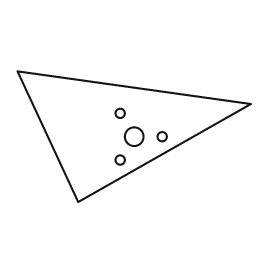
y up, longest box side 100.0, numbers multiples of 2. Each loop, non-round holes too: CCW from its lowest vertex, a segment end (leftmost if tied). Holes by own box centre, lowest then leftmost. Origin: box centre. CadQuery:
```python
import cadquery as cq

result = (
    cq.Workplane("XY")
    .moveTo(-24.0, -28.0)
    .lineTo(50.0, 14.0)
    .lineTo(-50.0, 28.0)
    .close()
    .moveTo(-6.0, -10.0)
    .circle(2.0)
    .moveTo(0.0, 0.0)
    .circle(4.0)
    .moveTo(12.0, 0.0)
    .circle(2.0)
    .moveTo(-6.0, 10.0)
    .circle(2.0)
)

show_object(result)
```